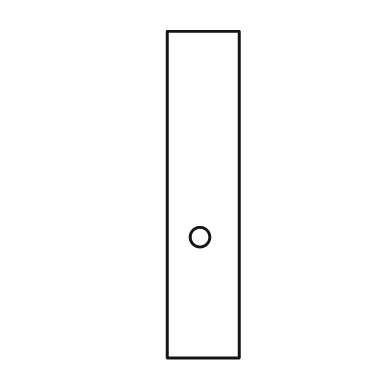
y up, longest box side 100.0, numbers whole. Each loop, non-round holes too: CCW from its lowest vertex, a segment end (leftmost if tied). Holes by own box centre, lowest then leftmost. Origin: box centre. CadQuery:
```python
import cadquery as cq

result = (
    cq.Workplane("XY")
    .moveTo(-11.0, -50.0)
    .lineTo(11.0, -50.0)
    .lineTo(11.0, 50.0)
    .lineTo(-11.0, 50.0)
    .close()
    .moveTo(-1.0, -13.0)
    .circle(3.0)
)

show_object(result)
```